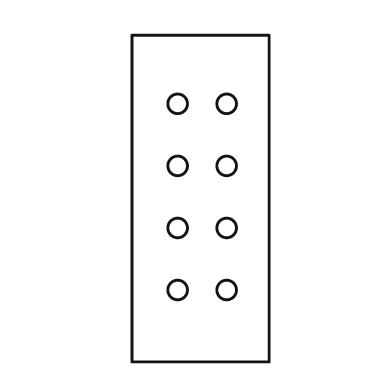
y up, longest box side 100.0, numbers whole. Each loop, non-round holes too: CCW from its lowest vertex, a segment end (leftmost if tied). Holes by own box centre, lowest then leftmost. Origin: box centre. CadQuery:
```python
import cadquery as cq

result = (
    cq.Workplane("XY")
    .moveTo(-21.0, -50.0)
    .lineTo(21.0, -50.0)
    .lineTo(21.0, 50.0)
    .lineTo(-21.0, 50.0)
    .close()
    .moveTo(-7.0, -28.0)
    .circle(3.0)
    .moveTo(8.0, -28.0)
    .circle(3.0)
    .moveTo(-7.0, -9.0)
    .circle(3.0)
    .moveTo(8.0, -9.0)
    .circle(3.0)
    .moveTo(-7.0, 10.0)
    .circle(3.0)
    .moveTo(8.0, 10.0)
    .circle(3.0)
    .moveTo(-7.0, 29.0)
    .circle(3.0)
    .moveTo(8.0, 29.0)
    .circle(3.0)
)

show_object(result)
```